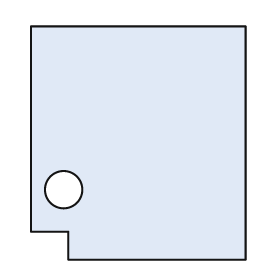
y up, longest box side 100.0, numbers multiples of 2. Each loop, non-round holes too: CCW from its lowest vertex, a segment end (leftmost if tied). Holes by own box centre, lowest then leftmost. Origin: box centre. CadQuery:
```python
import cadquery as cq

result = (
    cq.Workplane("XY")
    .moveTo(-30.0, -50.0)
    .lineTo(46.0, -50.0)
    .lineTo(46.0, 50.0)
    .lineTo(-46.0, 50.0)
    .lineTo(-46.0, -38.0)
    .lineTo(-30.0, -38.0)
    .close()
    .moveTo(-32.0, -20.0)
    .circle(8.0)
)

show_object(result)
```